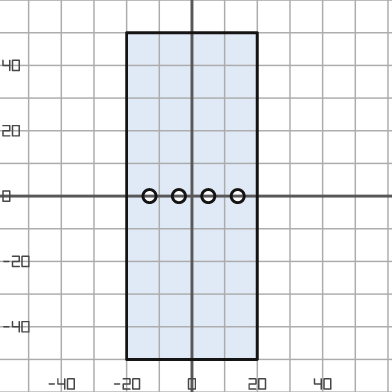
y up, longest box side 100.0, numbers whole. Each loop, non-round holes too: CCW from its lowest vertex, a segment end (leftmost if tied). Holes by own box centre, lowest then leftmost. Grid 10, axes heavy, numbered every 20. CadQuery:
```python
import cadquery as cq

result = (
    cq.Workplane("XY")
    .moveTo(-20.0, -50.0)
    .lineTo(20.0, -50.0)
    .lineTo(20.0, 50.0)
    .lineTo(-20.0, 50.0)
    .close()
    .moveTo(-13.0, 0.0)
    .circle(2.0)
    .moveTo(-4.0, 0.0)
    .circle(2.0)
    .moveTo(5.0, 0.0)
    .circle(2.0)
    .moveTo(14.0, 0.0)
    .circle(2.0)
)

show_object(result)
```